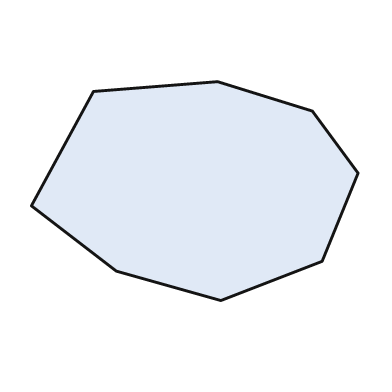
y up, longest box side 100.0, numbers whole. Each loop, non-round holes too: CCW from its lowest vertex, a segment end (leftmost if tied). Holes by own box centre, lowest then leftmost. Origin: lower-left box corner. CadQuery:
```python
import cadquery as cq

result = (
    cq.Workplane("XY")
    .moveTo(58.0, 0.0)
    .lineTo(89.0, 12.0)
    .lineTo(100.0, 39.0)
    .lineTo(86.0, 58.0)
    .lineTo(57.0, 67.0)
    .lineTo(19.0, 64.0)
    .lineTo(0.0, 29.0)
    .lineTo(26.0, 9.0)
    .close()
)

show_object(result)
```